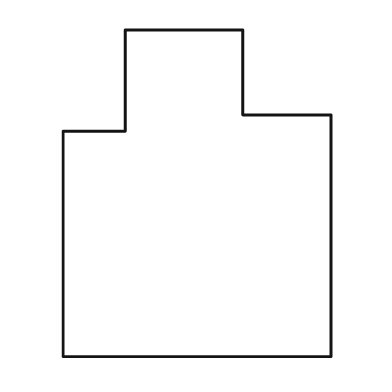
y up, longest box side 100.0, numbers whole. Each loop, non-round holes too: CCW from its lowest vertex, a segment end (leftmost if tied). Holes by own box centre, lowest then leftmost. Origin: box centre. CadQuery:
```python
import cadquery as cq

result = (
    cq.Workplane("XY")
    .moveTo(-41.0, -50.0)
    .lineTo(41.0, -50.0)
    .lineTo(41.0, 24.0)
    .lineTo(14.0, 24.0)
    .lineTo(14.0, 50.0)
    .lineTo(-22.0, 50.0)
    .lineTo(-22.0, 19.0)
    .lineTo(-41.0, 19.0)
    .close()
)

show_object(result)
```